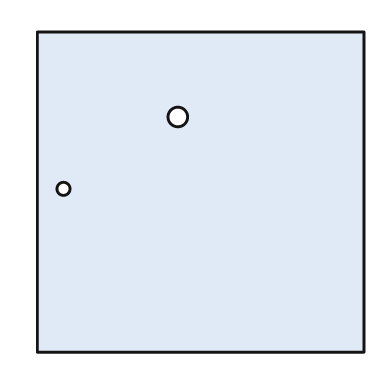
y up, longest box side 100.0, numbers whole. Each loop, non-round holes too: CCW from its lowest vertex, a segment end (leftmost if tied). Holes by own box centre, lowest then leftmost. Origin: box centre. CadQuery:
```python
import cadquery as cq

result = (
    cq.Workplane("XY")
    .moveTo(-50.0, -49.0)
    .lineTo(50.0, -49.0)
    .lineTo(50.0, 49.0)
    .lineTo(-50.0, 49.0)
    .close()
    .moveTo(-42.0, 1.0)
    .circle(2.0)
    .moveTo(-7.0, 23.0)
    .circle(3.0)
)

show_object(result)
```